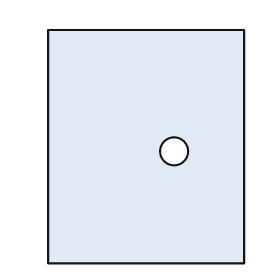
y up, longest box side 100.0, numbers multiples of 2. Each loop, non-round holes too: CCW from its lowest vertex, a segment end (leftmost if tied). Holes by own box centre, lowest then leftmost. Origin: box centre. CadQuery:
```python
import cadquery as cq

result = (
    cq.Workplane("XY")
    .moveTo(-42.0, -50.0)
    .lineTo(42.0, -50.0)
    .lineTo(42.0, 50.0)
    .lineTo(-42.0, 50.0)
    .close()
    .moveTo(12.0, -2.0)
    .circle(6.0)
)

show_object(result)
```